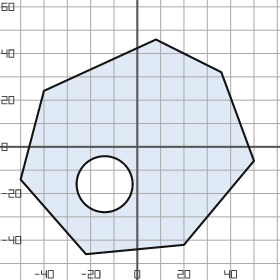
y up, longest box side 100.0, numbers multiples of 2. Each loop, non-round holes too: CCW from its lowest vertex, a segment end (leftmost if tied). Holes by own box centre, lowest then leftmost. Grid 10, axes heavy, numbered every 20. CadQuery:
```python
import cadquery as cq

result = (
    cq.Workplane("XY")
    .moveTo(-22.0, -46.0)
    .lineTo(20.0, -42.0)
    .lineTo(50.0, -6.0)
    .lineTo(36.0, 32.0)
    .lineTo(8.0, 46.0)
    .lineTo(-40.0, 24.0)
    .lineTo(-50.0, -14.0)
    .close()
    .moveTo(-14.0, -16.0)
    .circle(12.0)
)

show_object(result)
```